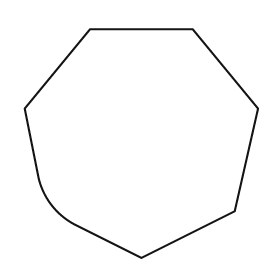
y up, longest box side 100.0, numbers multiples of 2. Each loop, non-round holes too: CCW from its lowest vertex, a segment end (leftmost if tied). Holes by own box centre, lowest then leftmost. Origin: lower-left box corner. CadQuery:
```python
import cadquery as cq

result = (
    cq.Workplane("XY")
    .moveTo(50.0, 0.0)
    .lineTo(90.0, 20.0)
    .lineTo(100.0, 64.0)
    .lineTo(72.0, 98.0)
    .lineTo(28.0, 98.0)
    .lineTo(0.0, 64.0)
    .lineTo(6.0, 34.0)
    .threePointArc((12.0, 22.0), (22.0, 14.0))
    .close()
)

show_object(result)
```